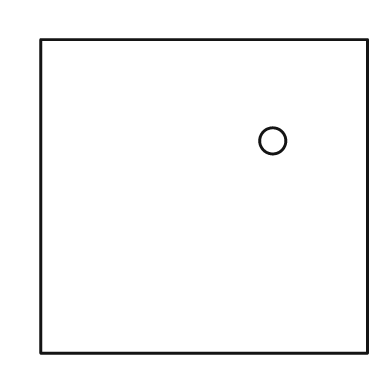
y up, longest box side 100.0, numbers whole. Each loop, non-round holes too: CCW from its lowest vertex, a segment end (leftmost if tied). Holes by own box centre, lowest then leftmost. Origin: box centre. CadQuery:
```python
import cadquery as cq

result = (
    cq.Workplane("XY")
    .moveTo(-50.0, -48.0)
    .lineTo(50.0, -48.0)
    .lineTo(50.0, 48.0)
    .lineTo(-50.0, 48.0)
    .close()
    .moveTo(21.0, 17.0)
    .circle(4.0)
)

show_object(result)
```